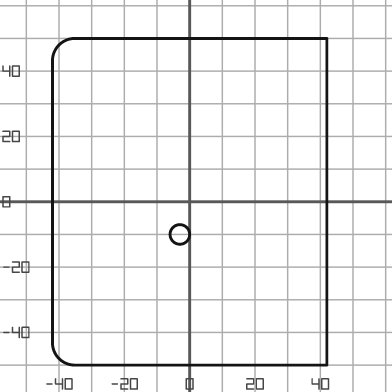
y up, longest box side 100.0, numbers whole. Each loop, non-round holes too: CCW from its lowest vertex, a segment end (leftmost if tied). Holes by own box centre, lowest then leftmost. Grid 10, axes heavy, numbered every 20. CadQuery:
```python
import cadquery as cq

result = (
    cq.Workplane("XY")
    .moveTo(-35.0, -50.0)
    .lineTo(42.0, -50.0)
    .lineTo(42.0, 50.0)
    .lineTo(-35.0, 50.0)
    .threePointArc((-40.0, 48.0), (-42.0, 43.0))
    .lineTo(-42.0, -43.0)
    .threePointArc((-40.0, -48.0), (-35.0, -50.0))
    .close()
    .moveTo(-3.0, -10.0)
    .circle(3.0)
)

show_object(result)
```